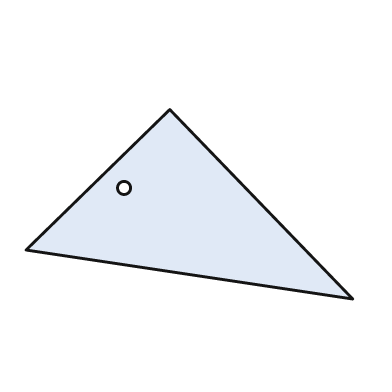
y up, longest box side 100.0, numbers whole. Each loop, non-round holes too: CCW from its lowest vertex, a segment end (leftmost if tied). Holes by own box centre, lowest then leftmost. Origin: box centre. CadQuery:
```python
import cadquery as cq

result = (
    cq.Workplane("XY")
    .moveTo(50.0, -29.0)
    .lineTo(-6.0, 29.0)
    .lineTo(-50.0, -14.0)
    .close()
    .moveTo(-20.0, 5.0)
    .circle(2.0)
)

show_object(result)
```